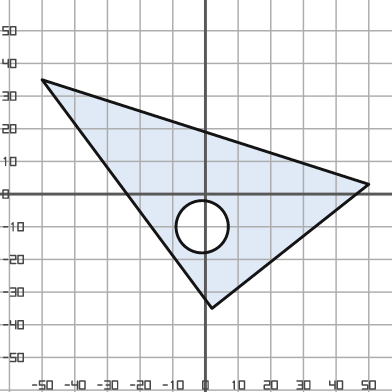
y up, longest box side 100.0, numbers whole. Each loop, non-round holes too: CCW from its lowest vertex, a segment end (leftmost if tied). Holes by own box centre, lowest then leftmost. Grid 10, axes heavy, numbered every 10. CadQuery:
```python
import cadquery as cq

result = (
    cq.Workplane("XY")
    .moveTo(2.0, -35.0)
    .lineTo(50.0, 3.0)
    .lineTo(-50.0, 35.0)
    .close()
    .moveTo(-1.0, -10.0)
    .circle(8.0)
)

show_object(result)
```